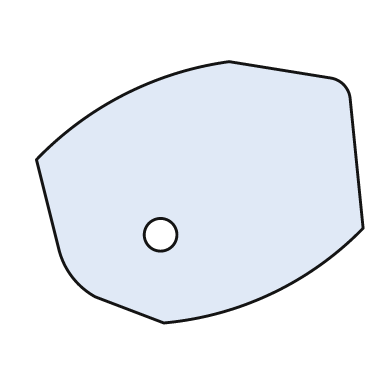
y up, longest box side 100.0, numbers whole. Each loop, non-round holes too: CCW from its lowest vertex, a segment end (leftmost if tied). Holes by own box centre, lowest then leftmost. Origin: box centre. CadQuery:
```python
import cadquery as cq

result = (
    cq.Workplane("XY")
    .moveTo(-11.0, -40.0)
    .threePointArc((22.0, -31.0), (50.0, -11.0))
    .lineTo(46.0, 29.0)
    .threePointArc((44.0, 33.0), (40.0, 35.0))
    .lineTo(9.0, 40.0)
    .threePointArc((-23.0, 30.0), (-50.0, 10.0))
    .lineTo(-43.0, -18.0)
    .threePointArc((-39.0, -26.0), (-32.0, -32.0))
    .close()
    .moveTo(-12.0, -13.0)
    .circle(5.0)
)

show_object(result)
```